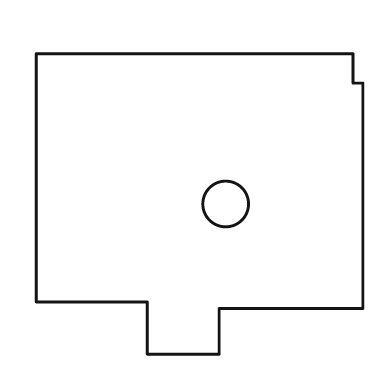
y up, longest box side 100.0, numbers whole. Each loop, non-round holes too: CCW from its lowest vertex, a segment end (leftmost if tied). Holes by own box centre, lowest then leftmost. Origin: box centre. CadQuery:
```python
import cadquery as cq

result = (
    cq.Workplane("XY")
    .moveTo(-16.0, -46.0)
    .lineTo(6.0, -46.0)
    .lineTo(6.0, -32.0)
    .lineTo(50.0, -32.0)
    .lineTo(50.0, 37.0)
    .lineTo(47.0, 37.0)
    .lineTo(47.0, 46.0)
    .lineTo(-50.0, 46.0)
    .lineTo(-50.0, -30.0)
    .lineTo(-16.0, -30.0)
    .close()
    .moveTo(8.0, 0.0)
    .circle(7.0)
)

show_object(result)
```